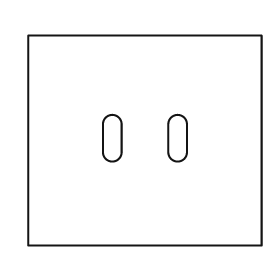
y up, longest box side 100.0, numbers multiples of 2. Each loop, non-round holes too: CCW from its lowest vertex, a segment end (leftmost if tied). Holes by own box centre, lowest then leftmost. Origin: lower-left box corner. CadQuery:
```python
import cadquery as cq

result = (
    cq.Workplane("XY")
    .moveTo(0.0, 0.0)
    .lineTo(100.0, 0.0)
    .lineTo(100.0, 90.0)
    .lineTo(0.0, 90.0)
    .close()
    .moveTo(32.0, 40.0)
    .threePointArc((36.0, 36.0), (40.0, 40.0))
    .lineTo(40.0, 52.0)
    .threePointArc((36.0, 56.0), (32.0, 52.0))
    .close()
    .moveTo(60.0, 40.0)
    .threePointArc((64.0, 36.0), (68.0, 40.0))
    .lineTo(68.0, 52.0)
    .threePointArc((64.0, 56.0), (60.0, 52.0))
    .close()
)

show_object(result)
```